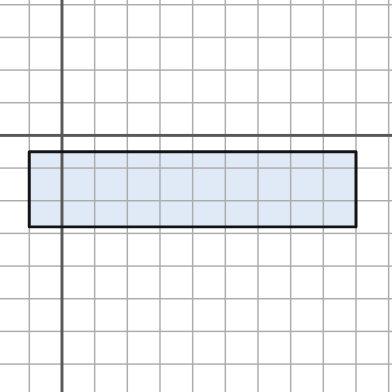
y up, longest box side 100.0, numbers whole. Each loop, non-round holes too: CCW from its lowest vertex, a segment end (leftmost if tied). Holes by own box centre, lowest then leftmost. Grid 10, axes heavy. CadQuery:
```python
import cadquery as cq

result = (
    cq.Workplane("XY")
    .moveTo(-10.0, -28.0)
    .lineTo(90.0, -28.0)
    .lineTo(90.0, -5.0)
    .lineTo(-10.0, -5.0)
    .close()
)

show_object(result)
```